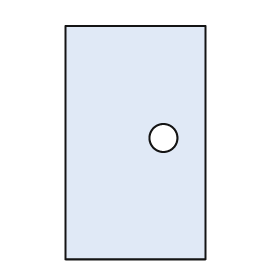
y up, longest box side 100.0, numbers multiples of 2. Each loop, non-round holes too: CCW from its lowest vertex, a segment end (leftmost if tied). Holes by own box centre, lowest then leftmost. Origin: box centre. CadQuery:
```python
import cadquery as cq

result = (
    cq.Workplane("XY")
    .moveTo(-30.0, -50.0)
    .lineTo(30.0, -50.0)
    .lineTo(30.0, 50.0)
    .lineTo(-30.0, 50.0)
    .close()
    .moveTo(12.0, 2.0)
    .circle(6.0)
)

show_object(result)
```